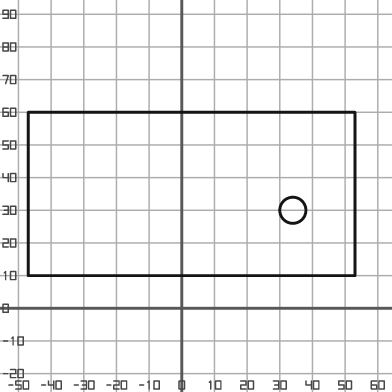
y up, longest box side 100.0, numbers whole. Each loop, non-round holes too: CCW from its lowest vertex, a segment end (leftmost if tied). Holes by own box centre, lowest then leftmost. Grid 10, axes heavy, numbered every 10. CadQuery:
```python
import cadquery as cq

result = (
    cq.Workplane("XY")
    .moveTo(-47.0, 10.0)
    .lineTo(53.0, 10.0)
    .lineTo(53.0, 60.0)
    .lineTo(-47.0, 60.0)
    .close()
    .moveTo(34.0, 30.0)
    .circle(4.0)
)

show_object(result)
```